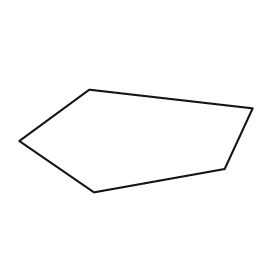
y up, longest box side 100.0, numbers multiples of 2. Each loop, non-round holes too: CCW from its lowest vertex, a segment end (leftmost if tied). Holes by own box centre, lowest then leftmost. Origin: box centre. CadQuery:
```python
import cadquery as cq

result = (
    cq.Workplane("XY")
    .moveTo(-18.0, -22.0)
    .lineTo(38.0, -12.0)
    .lineTo(50.0, 14.0)
    .lineTo(-20.0, 22.0)
    .lineTo(-50.0, 0.0)
    .close()
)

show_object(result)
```